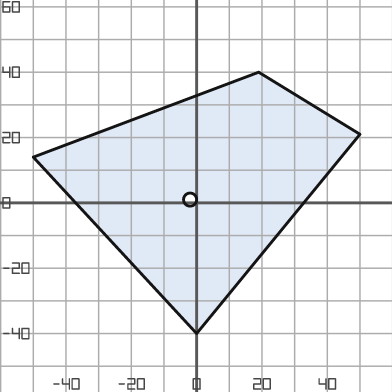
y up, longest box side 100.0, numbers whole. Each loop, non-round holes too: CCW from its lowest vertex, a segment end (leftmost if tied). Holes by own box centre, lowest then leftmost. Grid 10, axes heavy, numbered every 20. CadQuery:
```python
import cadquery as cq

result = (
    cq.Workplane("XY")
    .moveTo(0.0, -40.0)
    .lineTo(50.0, 21.0)
    .lineTo(19.0, 40.0)
    .lineTo(-50.0, 14.0)
    .close()
    .moveTo(-2.0, 1.0)
    .circle(2.0)
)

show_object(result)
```